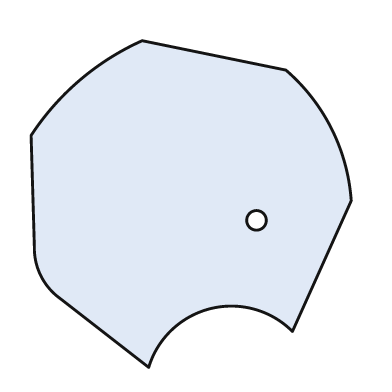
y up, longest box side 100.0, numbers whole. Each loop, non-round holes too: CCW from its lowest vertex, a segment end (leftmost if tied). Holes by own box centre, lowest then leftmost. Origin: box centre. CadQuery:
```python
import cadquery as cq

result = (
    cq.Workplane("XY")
    .moveTo(-13.0, -50.0)
    .threePointArc((6.0, -32.0), (31.0, -39.0))
    .lineTo(49.0, 1.0)
    .threePointArc((43.0, 23.0), (29.0, 41.0))
    .lineTo(-15.0, 50.0)
    .threePointArc((-34.0, 38.0), (-49.0, 21.0))
    .lineTo(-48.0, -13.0)
    .threePointArc((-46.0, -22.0), (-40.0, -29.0))
    .close()
    .moveTo(20.0, -5.0)
    .circle(3.0)
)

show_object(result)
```